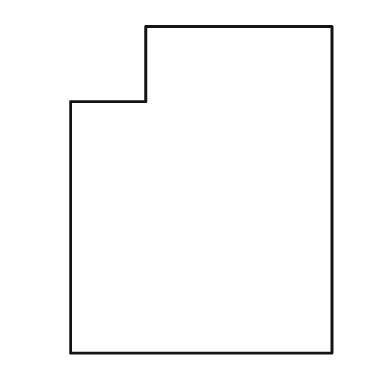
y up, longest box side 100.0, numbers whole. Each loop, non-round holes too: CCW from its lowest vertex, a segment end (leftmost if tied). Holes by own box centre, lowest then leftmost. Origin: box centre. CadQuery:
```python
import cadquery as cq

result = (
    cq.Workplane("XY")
    .moveTo(-40.0, -50.0)
    .lineTo(40.0, -50.0)
    .lineTo(40.0, 50.0)
    .lineTo(-17.0, 50.0)
    .lineTo(-17.0, 27.0)
    .lineTo(-40.0, 27.0)
    .close()
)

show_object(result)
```